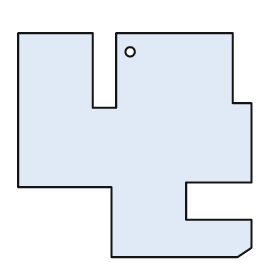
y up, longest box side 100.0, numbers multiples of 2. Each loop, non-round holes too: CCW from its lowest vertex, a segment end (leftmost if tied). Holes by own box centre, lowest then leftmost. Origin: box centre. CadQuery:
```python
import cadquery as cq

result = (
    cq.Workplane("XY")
    .moveTo(-10.0, -48.0)
    .lineTo(44.0, -48.0)
    .lineTo(50.0, -44.0)
    .lineTo(50.0, -32.0)
    .lineTo(22.0, -32.0)
    .lineTo(22.0, -16.0)
    .lineTo(50.0, -16.0)
    .lineTo(50.0, 18.0)
    .lineTo(42.0, 18.0)
    .lineTo(42.0, 48.0)
    .lineTo(-8.0, 48.0)
    .lineTo(-8.0, 16.0)
    .lineTo(-18.0, 16.0)
    .lineTo(-18.0, 48.0)
    .lineTo(-50.0, 48.0)
    .lineTo(-50.0, -18.0)
    .lineTo(-10.0, -18.0)
    .close()
    .moveTo(-2.0, 40.0)
    .circle(2.0)
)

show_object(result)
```